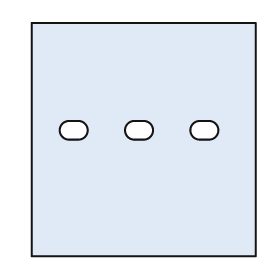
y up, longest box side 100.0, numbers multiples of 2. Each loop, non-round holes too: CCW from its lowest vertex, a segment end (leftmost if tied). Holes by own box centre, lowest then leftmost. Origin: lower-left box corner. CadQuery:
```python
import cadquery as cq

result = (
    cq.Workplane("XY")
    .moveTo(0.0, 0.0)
    .lineTo(96.0, 0.0)
    .lineTo(96.0, 100.0)
    .lineTo(0.0, 100.0)
    .close()
    .moveTo(16.0, 50.0)
    .lineTo(20.0, 50.0)
    .threePointArc((24.0, 54.0), (20.0, 58.0))
    .lineTo(16.0, 58.0)
    .threePointArc((12.0, 54.0), (16.0, 50.0))
    .close()
    .moveTo(44.0, 50.0)
    .lineTo(48.0, 50.0)
    .threePointArc((52.0, 54.0), (48.0, 58.0))
    .lineTo(44.0, 58.0)
    .threePointArc((40.0, 54.0), (44.0, 50.0))
    .close()
    .moveTo(72.0, 50.0)
    .lineTo(76.0, 50.0)
    .threePointArc((80.0, 54.0), (76.0, 58.0))
    .lineTo(72.0, 58.0)
    .threePointArc((68.0, 54.0), (72.0, 50.0))
    .close()
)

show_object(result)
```